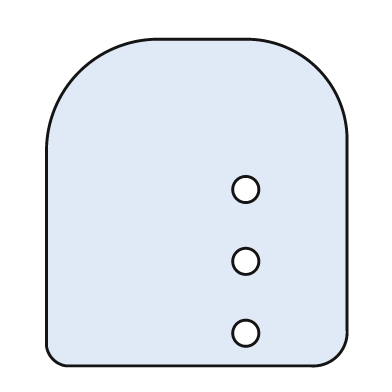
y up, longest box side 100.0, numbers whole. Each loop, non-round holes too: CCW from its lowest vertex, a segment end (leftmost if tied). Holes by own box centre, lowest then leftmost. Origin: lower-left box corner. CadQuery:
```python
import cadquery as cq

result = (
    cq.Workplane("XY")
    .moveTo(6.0, 0.0)
    .lineTo(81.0, 0.0)
    .threePointArc((89.0, 3.0), (92.0, 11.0))
    .lineTo(92.0, 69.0)
    .threePointArc((83.0, 91.0), (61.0, 100.0))
    .lineTo(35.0, 100.0)
    .threePointArc((10.0, 90.0), (0.0, 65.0))
    .lineTo(0.0, 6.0)
    .threePointArc((2.0, 2.0), (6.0, 0.0))
    .close()
    .moveTo(61.0, 10.0)
    .circle(4.0)
    .moveTo(61.0, 32.0)
    .circle(4.0)
    .moveTo(61.0, 54.0)
    .circle(4.0)
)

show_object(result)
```